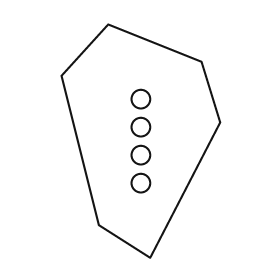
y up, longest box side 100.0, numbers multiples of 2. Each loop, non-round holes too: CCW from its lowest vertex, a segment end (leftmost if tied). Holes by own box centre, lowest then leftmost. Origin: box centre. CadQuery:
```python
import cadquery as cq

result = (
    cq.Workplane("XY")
    .moveTo(4.0, -50.0)
    .lineTo(34.0, 8.0)
    .lineTo(26.0, 34.0)
    .lineTo(-14.0, 50.0)
    .lineTo(-34.0, 28.0)
    .lineTo(-18.0, -36.0)
    .close()
    .moveTo(0.0, -18.0)
    .circle(4.0)
    .moveTo(0.0, -6.0)
    .circle(4.0)
    .moveTo(0.0, 6.0)
    .circle(4.0)
    .moveTo(0.0, 18.0)
    .circle(4.0)
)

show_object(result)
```